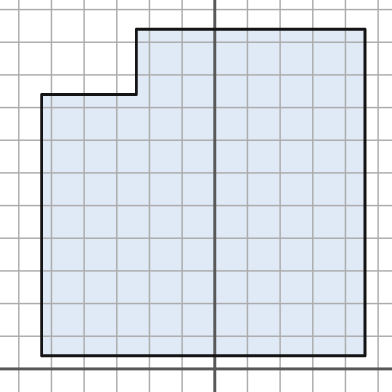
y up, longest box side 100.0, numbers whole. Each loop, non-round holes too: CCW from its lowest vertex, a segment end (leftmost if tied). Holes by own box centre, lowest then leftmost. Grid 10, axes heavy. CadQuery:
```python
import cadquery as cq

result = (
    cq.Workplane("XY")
    .moveTo(-53.0, 4.0)
    .lineTo(46.0, 4.0)
    .lineTo(46.0, 104.0)
    .lineTo(-24.0, 104.0)
    .lineTo(-24.0, 84.0)
    .lineTo(-53.0, 84.0)
    .close()
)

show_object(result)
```